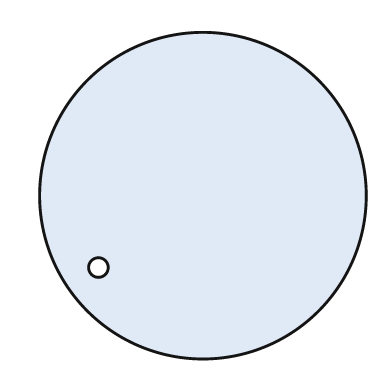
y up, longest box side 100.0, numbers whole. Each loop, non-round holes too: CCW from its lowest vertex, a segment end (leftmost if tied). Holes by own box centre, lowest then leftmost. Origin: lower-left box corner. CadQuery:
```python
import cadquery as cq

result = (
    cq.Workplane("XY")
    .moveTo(50.0, 50.0)
    .circle(50.0)
    .moveTo(18.0, 28.0)
    .circle(3.0)
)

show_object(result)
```